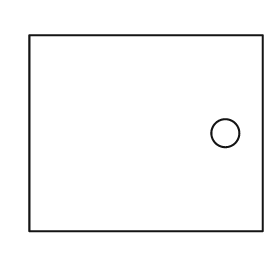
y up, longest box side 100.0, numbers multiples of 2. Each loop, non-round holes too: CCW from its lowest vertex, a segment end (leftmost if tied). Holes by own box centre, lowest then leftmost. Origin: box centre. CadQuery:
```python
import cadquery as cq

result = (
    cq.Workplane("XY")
    .moveTo(-50.0, -42.0)
    .lineTo(50.0, -42.0)
    .lineTo(50.0, 42.0)
    .lineTo(-50.0, 42.0)
    .close()
    .moveTo(34.0, 0.0)
    .circle(6.0)
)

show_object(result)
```